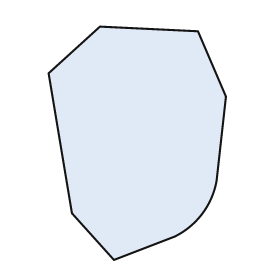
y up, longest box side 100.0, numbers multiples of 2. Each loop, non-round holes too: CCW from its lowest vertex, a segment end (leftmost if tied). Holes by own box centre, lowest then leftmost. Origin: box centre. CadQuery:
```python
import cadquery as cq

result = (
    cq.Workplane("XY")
    .moveTo(-10.0, -50.0)
    .lineTo(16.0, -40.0)
    .threePointArc((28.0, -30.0), (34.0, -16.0))
    .lineTo(38.0, 20.0)
    .lineTo(26.0, 48.0)
    .lineTo(-16.0, 50.0)
    .lineTo(-38.0, 30.0)
    .lineTo(-28.0, -30.0)
    .close()
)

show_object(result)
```